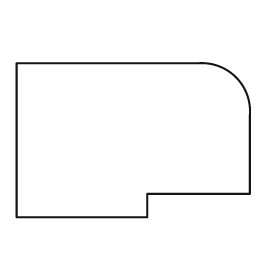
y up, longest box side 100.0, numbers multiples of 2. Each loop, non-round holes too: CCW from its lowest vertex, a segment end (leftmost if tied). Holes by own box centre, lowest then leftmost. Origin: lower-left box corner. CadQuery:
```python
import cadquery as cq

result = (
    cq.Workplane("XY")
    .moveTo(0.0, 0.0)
    .lineTo(56.0, 0.0)
    .lineTo(56.0, 10.0)
    .lineTo(100.0, 10.0)
    .lineTo(100.0, 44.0)
    .threePointArc((94.0, 60.0), (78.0, 66.0))
    .lineTo(0.0, 66.0)
    .close()
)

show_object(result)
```